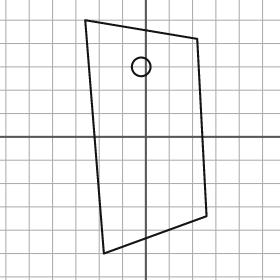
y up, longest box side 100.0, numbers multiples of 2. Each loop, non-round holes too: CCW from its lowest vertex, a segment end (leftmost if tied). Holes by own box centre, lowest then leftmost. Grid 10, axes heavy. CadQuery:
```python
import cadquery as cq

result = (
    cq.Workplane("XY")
    .moveTo(-18.0, -50.0)
    .lineTo(26.0, -34.0)
    .lineTo(22.0, 42.0)
    .lineTo(-26.0, 50.0)
    .close()
    .moveTo(-2.0, 30.0)
    .circle(4.0)
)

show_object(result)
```